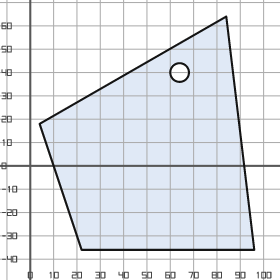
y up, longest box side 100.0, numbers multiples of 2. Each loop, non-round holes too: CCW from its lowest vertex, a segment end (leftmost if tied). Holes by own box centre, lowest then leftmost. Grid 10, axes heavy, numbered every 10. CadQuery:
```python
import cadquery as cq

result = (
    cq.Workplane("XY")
    .moveTo(22.0, -36.0)
    .lineTo(96.0, -36.0)
    .lineTo(84.0, 64.0)
    .lineTo(4.0, 18.0)
    .close()
    .moveTo(64.0, 40.0)
    .circle(4.0)
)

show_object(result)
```